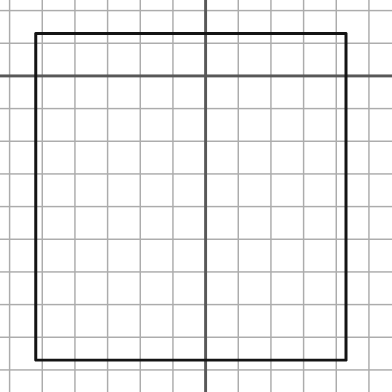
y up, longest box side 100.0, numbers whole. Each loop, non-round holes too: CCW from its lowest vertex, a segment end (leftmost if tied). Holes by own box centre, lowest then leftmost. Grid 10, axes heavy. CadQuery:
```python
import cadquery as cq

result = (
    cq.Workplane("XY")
    .moveTo(-52.0, -87.0)
    .lineTo(43.0, -87.0)
    .lineTo(43.0, 13.0)
    .lineTo(-52.0, 13.0)
    .close()
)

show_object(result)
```